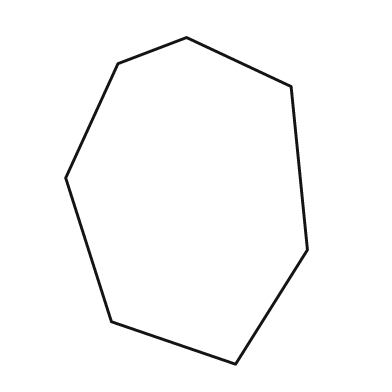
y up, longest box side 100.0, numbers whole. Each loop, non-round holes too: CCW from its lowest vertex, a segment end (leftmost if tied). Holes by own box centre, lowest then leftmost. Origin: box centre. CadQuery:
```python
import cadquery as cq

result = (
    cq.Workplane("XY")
    .moveTo(15.0, -50.0)
    .lineTo(37.0, -15.0)
    .lineTo(32.0, 35.0)
    .lineTo(0.0, 50.0)
    .lineTo(-21.0, 42.0)
    .lineTo(-37.0, 7.0)
    .lineTo(-23.0, -37.0)
    .close()
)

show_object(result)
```